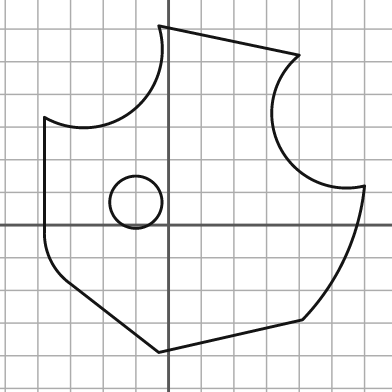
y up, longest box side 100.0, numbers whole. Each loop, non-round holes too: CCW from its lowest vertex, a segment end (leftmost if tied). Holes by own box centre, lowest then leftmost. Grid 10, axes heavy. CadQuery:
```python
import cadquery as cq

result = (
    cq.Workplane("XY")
    .moveTo(-3.0, -39.0)
    .lineTo(41.0, -29.0)
    .threePointArc((54.0, -10.0), (60.0, 12.0))
    .threePointArc((34.0, 24.0), (40.0, 52.0))
    .lineTo(-3.0, 61.0)
    .threePointArc((-11.0, 35.0), (-38.0, 33.0))
    .lineTo(-38.0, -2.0)
    .threePointArc((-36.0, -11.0), (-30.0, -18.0))
    .close()
    .moveTo(-10.0, 7.0)
    .circle(8.0)
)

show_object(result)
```